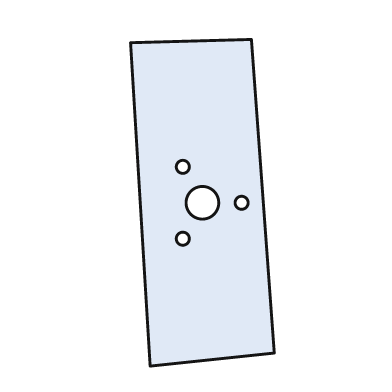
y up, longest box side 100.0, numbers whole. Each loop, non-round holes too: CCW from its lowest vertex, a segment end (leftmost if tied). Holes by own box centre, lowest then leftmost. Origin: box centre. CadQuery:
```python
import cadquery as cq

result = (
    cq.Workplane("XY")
    .moveTo(-16.0, -50.0)
    .lineTo(22.0, -46.0)
    .lineTo(15.0, 50.0)
    .lineTo(-22.0, 49.0)
    .close()
    .moveTo(-6.0, -11.0)
    .circle(2.0)
    .moveTo(0.0, 0.0)
    .circle(5.0)
    .moveTo(12.0, 0.0)
    .circle(2.0)
    .moveTo(-6.0, 11.0)
    .circle(2.0)
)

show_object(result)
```